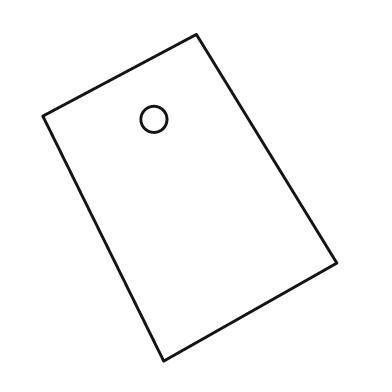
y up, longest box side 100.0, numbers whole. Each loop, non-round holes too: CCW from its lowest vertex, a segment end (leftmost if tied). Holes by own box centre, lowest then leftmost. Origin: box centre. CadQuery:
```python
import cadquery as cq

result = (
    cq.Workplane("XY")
    .moveTo(-8.0, -50.0)
    .lineTo(45.0, -20.0)
    .lineTo(2.0, 50.0)
    .lineTo(-45.0, 25.0)
    .close()
    .moveTo(-11.0, 24.0)
    .circle(4.0)
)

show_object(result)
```